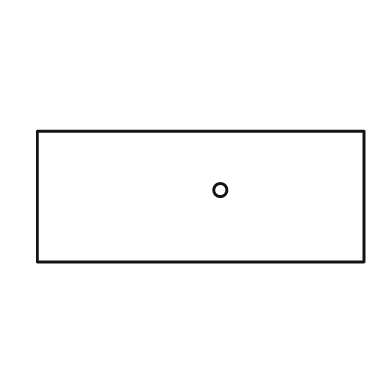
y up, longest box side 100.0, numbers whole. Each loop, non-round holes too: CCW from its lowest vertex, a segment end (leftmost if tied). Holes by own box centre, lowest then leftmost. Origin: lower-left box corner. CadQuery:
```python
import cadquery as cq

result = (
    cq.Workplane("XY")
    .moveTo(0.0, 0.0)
    .lineTo(100.0, 0.0)
    .lineTo(100.0, 40.0)
    .lineTo(0.0, 40.0)
    .close()
    .moveTo(56.0, 22.0)
    .circle(2.0)
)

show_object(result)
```